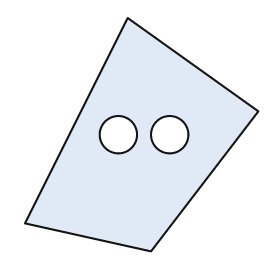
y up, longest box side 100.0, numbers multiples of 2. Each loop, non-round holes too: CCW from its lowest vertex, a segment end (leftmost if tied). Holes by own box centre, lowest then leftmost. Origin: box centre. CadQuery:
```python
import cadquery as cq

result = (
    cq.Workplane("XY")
    .moveTo(4.0, -50.0)
    .lineTo(50.0, 10.0)
    .lineTo(-6.0, 50.0)
    .lineTo(-50.0, -38.0)
    .close()
    .moveTo(-10.0, 0.0)
    .circle(8.0)
    .moveTo(12.0, 0.0)
    .circle(8.0)
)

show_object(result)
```